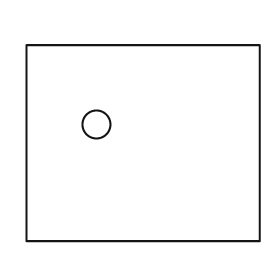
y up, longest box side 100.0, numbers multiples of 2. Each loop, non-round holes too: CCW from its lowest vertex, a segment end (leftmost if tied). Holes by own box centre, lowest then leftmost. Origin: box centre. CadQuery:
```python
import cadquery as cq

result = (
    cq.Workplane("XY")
    .moveTo(-50.0, -42.0)
    .lineTo(50.0, -42.0)
    .lineTo(50.0, 42.0)
    .lineTo(-50.0, 42.0)
    .close()
    .moveTo(-20.0, 8.0)
    .circle(6.0)
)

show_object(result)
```